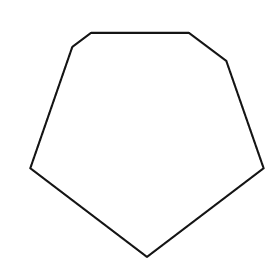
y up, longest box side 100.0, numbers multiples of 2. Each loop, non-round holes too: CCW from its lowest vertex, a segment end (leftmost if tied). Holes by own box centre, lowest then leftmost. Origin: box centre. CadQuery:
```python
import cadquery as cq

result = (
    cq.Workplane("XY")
    .moveTo(0.0, -48.0)
    .lineTo(50.0, -10.0)
    .lineTo(34.0, 36.0)
    .lineTo(18.0, 48.0)
    .lineTo(-24.0, 48.0)
    .lineTo(-32.0, 42.0)
    .lineTo(-50.0, -10.0)
    .close()
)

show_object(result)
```